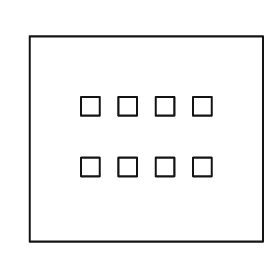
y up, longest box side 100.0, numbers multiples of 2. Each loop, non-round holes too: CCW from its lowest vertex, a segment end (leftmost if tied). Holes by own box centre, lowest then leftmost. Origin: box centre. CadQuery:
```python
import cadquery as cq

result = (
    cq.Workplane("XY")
    .moveTo(-50.0, -44.0)
    .lineTo(50.0, -44.0)
    .lineTo(50.0, 44.0)
    .lineTo(-50.0, 44.0)
    .close()
    .moveTo(-28.0, -16.0)
    .lineTo(-20.0, -16.0)
    .lineTo(-20.0, -8.0)
    .lineTo(-28.0, -8.0)
    .close()
    .moveTo(-12.0, -16.0)
    .lineTo(-4.0, -16.0)
    .lineTo(-4.0, -8.0)
    .lineTo(-12.0, -8.0)
    .close()
    .moveTo(4.0, -16.0)
    .lineTo(12.0, -16.0)
    .lineTo(12.0, -8.0)
    .lineTo(4.0, -8.0)
    .close()
    .moveTo(20.0, -16.0)
    .lineTo(28.0, -16.0)
    .lineTo(28.0, -8.0)
    .lineTo(20.0, -8.0)
    .close()
    .moveTo(-28.0, 10.0)
    .lineTo(-20.0, 10.0)
    .lineTo(-20.0, 18.0)
    .lineTo(-28.0, 18.0)
    .close()
    .moveTo(-12.0, 10.0)
    .lineTo(-4.0, 10.0)
    .lineTo(-4.0, 18.0)
    .lineTo(-12.0, 18.0)
    .close()
    .moveTo(4.0, 10.0)
    .lineTo(12.0, 10.0)
    .lineTo(12.0, 18.0)
    .lineTo(4.0, 18.0)
    .close()
    .moveTo(20.0, 10.0)
    .lineTo(28.0, 10.0)
    .lineTo(28.0, 18.0)
    .lineTo(20.0, 18.0)
    .close()
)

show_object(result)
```